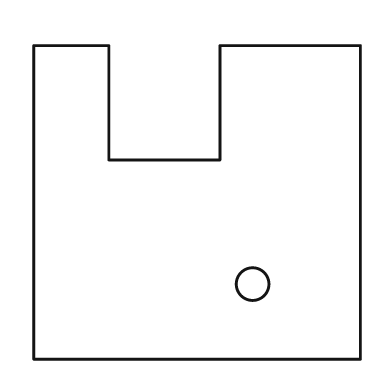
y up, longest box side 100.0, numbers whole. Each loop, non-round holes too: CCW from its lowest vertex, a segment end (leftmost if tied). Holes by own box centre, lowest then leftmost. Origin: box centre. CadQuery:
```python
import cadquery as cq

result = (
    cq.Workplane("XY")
    .moveTo(-50.0, -48.0)
    .lineTo(50.0, -48.0)
    .lineTo(50.0, 48.0)
    .lineTo(7.0, 48.0)
    .lineTo(7.0, 13.0)
    .lineTo(-27.0, 13.0)
    .lineTo(-27.0, 48.0)
    .lineTo(-50.0, 48.0)
    .close()
    .moveTo(17.0, -25.0)
    .circle(5.0)
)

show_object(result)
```